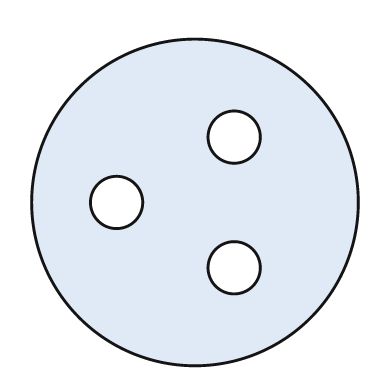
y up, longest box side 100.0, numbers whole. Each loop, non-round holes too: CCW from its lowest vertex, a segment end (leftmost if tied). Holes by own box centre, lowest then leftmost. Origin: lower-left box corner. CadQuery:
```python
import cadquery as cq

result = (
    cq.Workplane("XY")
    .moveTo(50.0, 50.0)
    .circle(50.0)
    .moveTo(62.0, 30.0)
    .circle(8.0)
    .moveTo(26.0, 50.0)
    .circle(8.0)
    .moveTo(62.0, 70.0)
    .circle(8.0)
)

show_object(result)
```